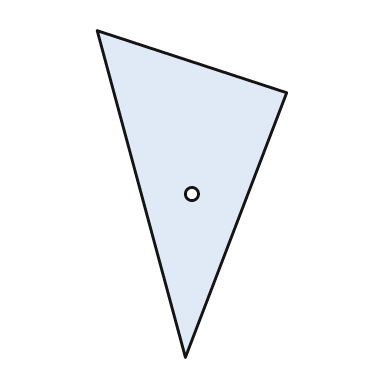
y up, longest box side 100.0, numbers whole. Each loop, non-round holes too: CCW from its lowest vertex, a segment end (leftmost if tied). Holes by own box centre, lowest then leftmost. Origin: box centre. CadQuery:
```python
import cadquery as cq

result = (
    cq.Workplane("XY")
    .moveTo(-2.0, -50.0)
    .lineTo(29.0, 31.0)
    .lineTo(-29.0, 50.0)
    .close()
    .moveTo(0.0, 0.0)
    .circle(2.0)
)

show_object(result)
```